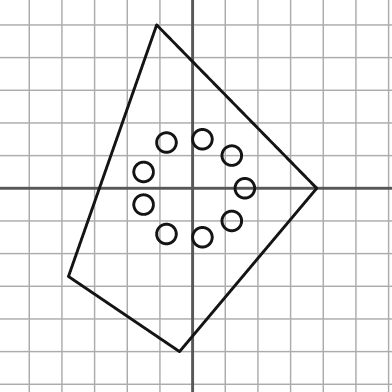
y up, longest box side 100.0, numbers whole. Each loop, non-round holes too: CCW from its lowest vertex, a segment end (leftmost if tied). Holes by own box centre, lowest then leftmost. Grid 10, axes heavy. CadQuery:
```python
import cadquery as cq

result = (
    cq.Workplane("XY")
    .moveTo(-4.0, -50.0)
    .lineTo(38.0, 0.0)
    .lineTo(-11.0, 50.0)
    .lineTo(-38.0, -27.0)
    .close()
    .moveTo(3.0, -15.0)
    .circle(3.0)
    .moveTo(-8.0, -14.0)
    .circle(3.0)
    .moveTo(12.0, -10.0)
    .circle(3.0)
    .moveTo(-15.0, -5.0)
    .circle(3.0)
    .moveTo(16.0, 0.0)
    .circle(3.0)
    .moveTo(-15.0, 5.0)
    .circle(3.0)
    .moveTo(12.0, 10.0)
    .circle(3.0)
    .moveTo(-8.0, 14.0)
    .circle(3.0)
    .moveTo(3.0, 15.0)
    .circle(3.0)
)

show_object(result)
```